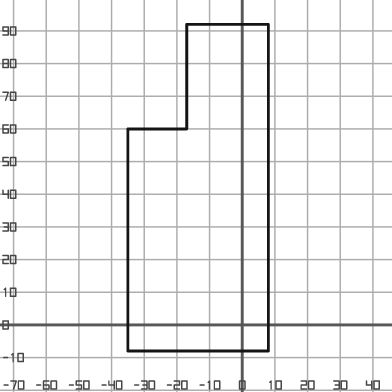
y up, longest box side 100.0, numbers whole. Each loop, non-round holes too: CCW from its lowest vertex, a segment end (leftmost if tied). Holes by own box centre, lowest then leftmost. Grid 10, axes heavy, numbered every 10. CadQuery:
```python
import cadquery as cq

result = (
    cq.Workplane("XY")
    .moveTo(-35.0, -8.0)
    .lineTo(8.0, -8.0)
    .lineTo(8.0, 92.0)
    .lineTo(-17.0, 92.0)
    .lineTo(-17.0, 60.0)
    .lineTo(-35.0, 60.0)
    .close()
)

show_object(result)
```